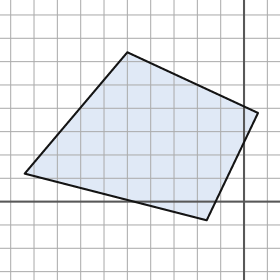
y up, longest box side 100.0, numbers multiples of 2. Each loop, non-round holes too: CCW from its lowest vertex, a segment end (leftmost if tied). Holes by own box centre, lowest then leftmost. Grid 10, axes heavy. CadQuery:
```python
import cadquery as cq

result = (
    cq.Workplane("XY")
    .moveTo(-16.0, -8.0)
    .lineTo(6.0, 38.0)
    .lineTo(-50.0, 64.0)
    .lineTo(-94.0, 12.0)
    .close()
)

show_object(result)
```